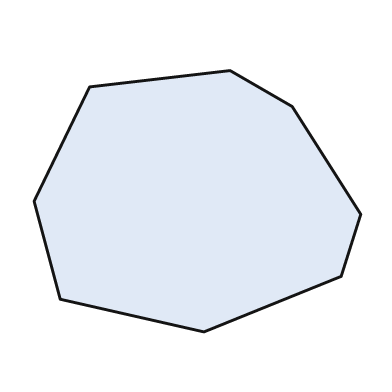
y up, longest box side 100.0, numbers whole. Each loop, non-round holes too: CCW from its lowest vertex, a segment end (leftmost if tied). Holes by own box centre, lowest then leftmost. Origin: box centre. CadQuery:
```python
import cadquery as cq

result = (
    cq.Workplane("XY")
    .moveTo(2.0, -40.0)
    .lineTo(44.0, -23.0)
    .lineTo(50.0, -4.0)
    .lineTo(29.0, 29.0)
    .lineTo(10.0, 40.0)
    .lineTo(-33.0, 35.0)
    .lineTo(-50.0, 0.0)
    .lineTo(-42.0, -30.0)
    .close()
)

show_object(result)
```